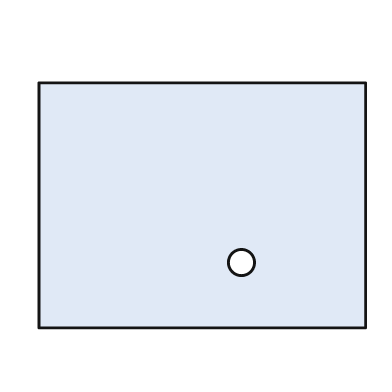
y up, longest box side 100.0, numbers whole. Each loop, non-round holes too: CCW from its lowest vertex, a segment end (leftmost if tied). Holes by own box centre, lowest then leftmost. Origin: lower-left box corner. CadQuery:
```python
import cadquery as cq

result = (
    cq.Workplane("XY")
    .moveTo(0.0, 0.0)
    .lineTo(100.0, 0.0)
    .lineTo(100.0, 75.0)
    .lineTo(0.0, 75.0)
    .close()
    .moveTo(62.0, 20.0)
    .circle(4.0)
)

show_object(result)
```